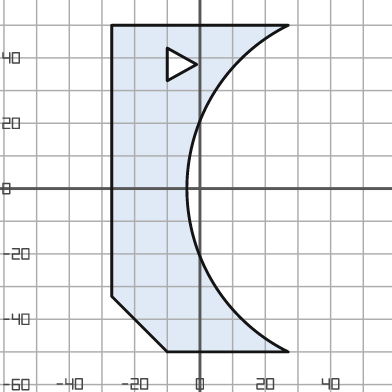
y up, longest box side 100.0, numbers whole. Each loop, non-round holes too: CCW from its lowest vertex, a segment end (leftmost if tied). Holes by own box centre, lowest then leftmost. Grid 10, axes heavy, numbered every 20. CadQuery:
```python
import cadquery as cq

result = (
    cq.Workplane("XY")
    .moveTo(-10.0, -50.0)
    .lineTo(27.0, -50.0)
    .threePointArc((-4.0, 0.0), (27.0, 50.0))
    .lineTo(-27.0, 50.0)
    .lineTo(-27.0, -33.0)
    .close()
    .moveTo(-10.0, 33.0)
    .lineTo(-1.0, 38.0)
    .lineTo(-10.0, 43.0)
    .close()
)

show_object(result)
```